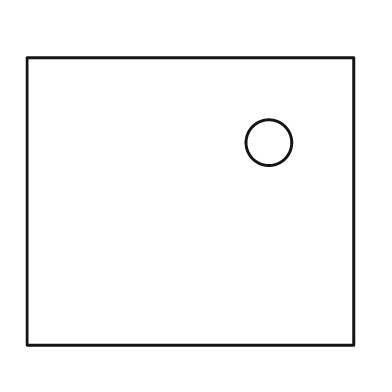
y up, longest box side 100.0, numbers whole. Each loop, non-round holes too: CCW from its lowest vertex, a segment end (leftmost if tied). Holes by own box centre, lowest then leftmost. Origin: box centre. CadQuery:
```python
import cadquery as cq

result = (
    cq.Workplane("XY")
    .moveTo(-50.0, -44.0)
    .lineTo(50.0, -44.0)
    .lineTo(50.0, 44.0)
    .lineTo(-50.0, 44.0)
    .close()
    .moveTo(24.0, 18.0)
    .circle(7.0)
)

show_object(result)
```